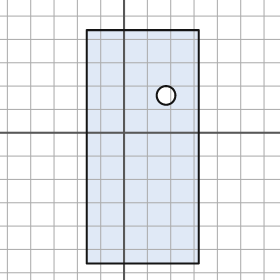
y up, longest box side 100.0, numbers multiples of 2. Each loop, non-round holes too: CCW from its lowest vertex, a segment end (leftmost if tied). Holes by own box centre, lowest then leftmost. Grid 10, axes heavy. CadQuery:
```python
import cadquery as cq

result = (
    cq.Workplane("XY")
    .moveTo(-16.0, -56.0)
    .lineTo(32.0, -56.0)
    .lineTo(32.0, 44.0)
    .lineTo(-16.0, 44.0)
    .close()
    .moveTo(18.0, 16.0)
    .circle(4.0)
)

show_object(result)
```